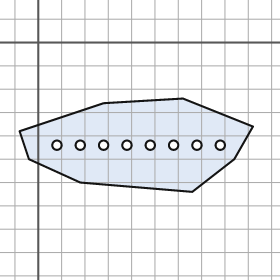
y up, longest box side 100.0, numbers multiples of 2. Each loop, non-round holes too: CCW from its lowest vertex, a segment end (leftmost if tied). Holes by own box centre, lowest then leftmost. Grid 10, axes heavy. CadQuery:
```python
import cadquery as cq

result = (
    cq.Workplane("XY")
    .moveTo(66.0, -64.0)
    .lineTo(84.0, -50.0)
    .lineTo(92.0, -36.0)
    .lineTo(62.0, -24.0)
    .lineTo(28.0, -26.0)
    .lineTo(-8.0, -38.0)
    .lineTo(-4.0, -50.0)
    .lineTo(18.0, -60.0)
    .close()
    .moveTo(8.0, -44.0)
    .circle(2.0)
    .moveTo(18.0, -44.0)
    .circle(2.0)
    .moveTo(28.0, -44.0)
    .circle(2.0)
    .moveTo(38.0, -44.0)
    .circle(2.0)
    .moveTo(48.0, -44.0)
    .circle(2.0)
    .moveTo(58.0, -44.0)
    .circle(2.0)
    .moveTo(68.0, -44.0)
    .circle(2.0)
    .moveTo(78.0, -44.0)
    .circle(2.0)
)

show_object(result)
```